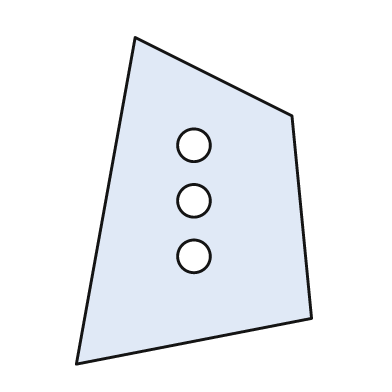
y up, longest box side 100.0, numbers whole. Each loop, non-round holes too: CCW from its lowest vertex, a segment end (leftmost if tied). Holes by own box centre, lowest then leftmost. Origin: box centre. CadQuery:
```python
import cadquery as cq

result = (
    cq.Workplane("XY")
    .moveTo(-36.0, -50.0)
    .lineTo(36.0, -36.0)
    .lineTo(30.0, 26.0)
    .lineTo(-18.0, 50.0)
    .close()
    .moveTo(0.0, -17.0)
    .circle(5.0)
    .moveTo(0.0, 0.0)
    .circle(5.0)
    .moveTo(0.0, 17.0)
    .circle(5.0)
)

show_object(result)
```